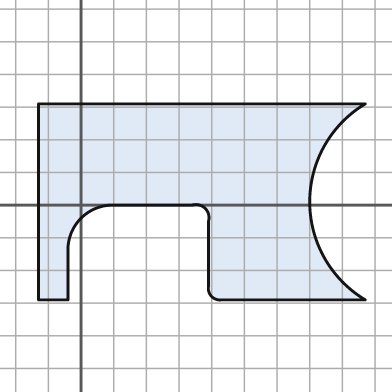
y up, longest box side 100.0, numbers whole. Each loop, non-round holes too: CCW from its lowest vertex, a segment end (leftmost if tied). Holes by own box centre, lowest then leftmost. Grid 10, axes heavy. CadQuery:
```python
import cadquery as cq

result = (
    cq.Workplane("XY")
    .moveTo(-13.0, -29.0)
    .lineTo(-4.0, -29.0)
    .lineTo(-4.0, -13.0)
    .threePointArc((0.0, -4.0), (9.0, 0.0))
    .lineTo(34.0, 0.0)
    .threePointArc((38.0, -1.0), (39.0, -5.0))
    .lineTo(39.0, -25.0)
    .threePointArc((40.0, -28.0), (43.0, -29.0))
    .lineTo(87.0, -29.0)
    .threePointArc((70.0, 1.0), (87.0, 31.0))
    .lineTo(-13.0, 31.0)
    .close()
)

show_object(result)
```